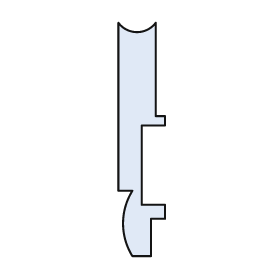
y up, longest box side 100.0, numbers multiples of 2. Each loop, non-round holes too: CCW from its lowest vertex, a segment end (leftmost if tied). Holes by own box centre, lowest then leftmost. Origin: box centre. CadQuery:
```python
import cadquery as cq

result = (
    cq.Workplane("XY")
    .moveTo(-4.0, -50.0)
    .lineTo(4.0, -50.0)
    .lineTo(4.0, -34.0)
    .lineTo(10.0, -34.0)
    .lineTo(10.0, -28.0)
    .lineTo(0.0, -28.0)
    .lineTo(0.0, 6.0)
    .lineTo(10.0, 6.0)
    .lineTo(10.0, 10.0)
    .lineTo(6.0, 10.0)
    .lineTo(6.0, 50.0)
    .threePointArc((-2.0, 46.0), (-10.0, 50.0))
    .lineTo(-10.0, -22.0)
    .lineTo(-4.0, -22.0)
    .threePointArc((-8.0, -36.0), (-4.0, -50.0))
    .close()
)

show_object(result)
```